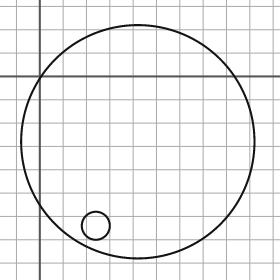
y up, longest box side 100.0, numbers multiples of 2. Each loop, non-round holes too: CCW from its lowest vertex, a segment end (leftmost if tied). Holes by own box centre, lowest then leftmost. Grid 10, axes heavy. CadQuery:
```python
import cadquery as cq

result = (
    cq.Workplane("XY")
    .moveTo(42.0, -28.0)
    .circle(50.0)
    .moveTo(24.0, -64.0)
    .circle(6.0)
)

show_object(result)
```